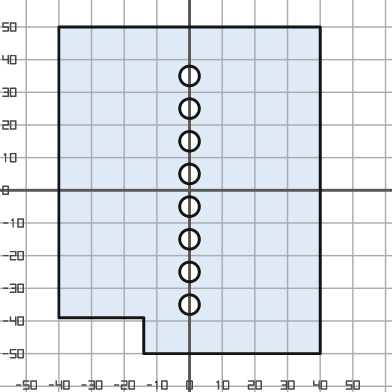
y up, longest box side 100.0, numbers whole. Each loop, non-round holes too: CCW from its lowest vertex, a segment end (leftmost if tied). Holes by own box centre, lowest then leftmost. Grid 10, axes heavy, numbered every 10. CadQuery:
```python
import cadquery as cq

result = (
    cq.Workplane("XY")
    .moveTo(-14.0, -50.0)
    .lineTo(40.0, -50.0)
    .lineTo(40.0, 50.0)
    .lineTo(-40.0, 50.0)
    .lineTo(-40.0, -39.0)
    .lineTo(-14.0, -39.0)
    .close()
    .moveTo(0.0, -35.0)
    .circle(3.0)
    .moveTo(0.0, -25.0)
    .circle(3.0)
    .moveTo(0.0, -15.0)
    .circle(3.0)
    .moveTo(0.0, -5.0)
    .circle(3.0)
    .moveTo(0.0, 5.0)
    .circle(3.0)
    .moveTo(0.0, 15.0)
    .circle(3.0)
    .moveTo(0.0, 25.0)
    .circle(3.0)
    .moveTo(0.0, 35.0)
    .circle(3.0)
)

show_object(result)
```